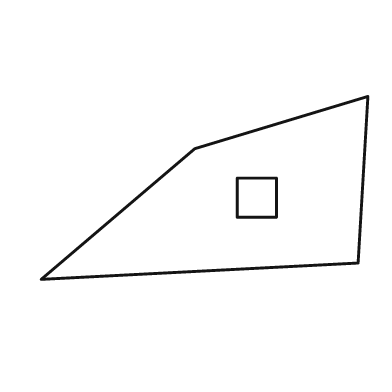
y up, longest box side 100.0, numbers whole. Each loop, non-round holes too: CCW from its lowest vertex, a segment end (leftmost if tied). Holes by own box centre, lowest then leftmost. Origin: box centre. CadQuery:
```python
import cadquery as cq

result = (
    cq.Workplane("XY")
    .moveTo(-50.0, -28.0)
    .lineTo(47.0, -23.0)
    .lineTo(50.0, 28.0)
    .lineTo(-3.0, 12.0)
    .close()
    .moveTo(10.0, -9.0)
    .lineTo(22.0, -9.0)
    .lineTo(22.0, 3.0)
    .lineTo(10.0, 3.0)
    .close()
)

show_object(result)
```